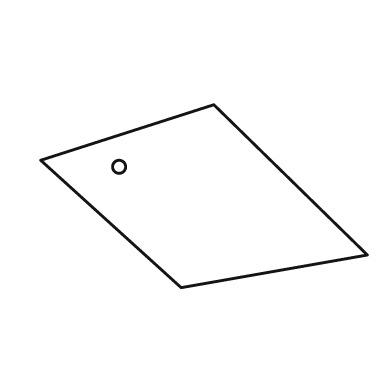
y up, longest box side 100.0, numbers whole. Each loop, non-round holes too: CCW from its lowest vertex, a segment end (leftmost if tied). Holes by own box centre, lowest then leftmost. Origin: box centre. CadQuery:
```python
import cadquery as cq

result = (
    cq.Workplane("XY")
    .moveTo(-7.0, -28.0)
    .lineTo(50.0, -18.0)
    .lineTo(3.0, 28.0)
    .lineTo(-50.0, 11.0)
    .close()
    .moveTo(-26.0, 9.0)
    .circle(2.0)
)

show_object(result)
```